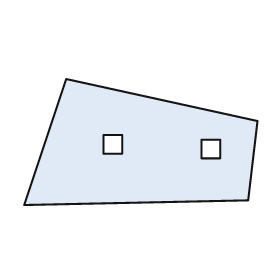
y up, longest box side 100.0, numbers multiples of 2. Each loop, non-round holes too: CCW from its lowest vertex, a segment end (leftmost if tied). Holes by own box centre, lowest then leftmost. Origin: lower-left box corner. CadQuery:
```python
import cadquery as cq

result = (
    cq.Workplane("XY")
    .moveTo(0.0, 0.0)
    .lineTo(96.0, 2.0)
    .lineTo(100.0, 36.0)
    .lineTo(18.0, 54.0)
    .close()
    .moveTo(76.0, 20.0)
    .lineTo(84.0, 20.0)
    .lineTo(84.0, 28.0)
    .lineTo(76.0, 28.0)
    .close()
    .moveTo(34.0, 22.0)
    .lineTo(42.0, 22.0)
    .lineTo(42.0, 30.0)
    .lineTo(34.0, 30.0)
    .close()
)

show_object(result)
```